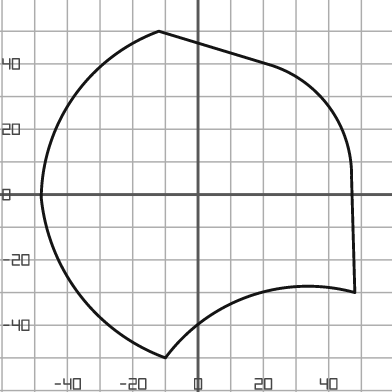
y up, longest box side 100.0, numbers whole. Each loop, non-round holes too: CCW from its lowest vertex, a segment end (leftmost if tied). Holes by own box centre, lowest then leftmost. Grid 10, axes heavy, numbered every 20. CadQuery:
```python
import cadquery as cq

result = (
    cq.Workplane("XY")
    .moveTo(-10.0, -50.0)
    .threePointArc((16.0, -31.0), (48.0, -30.0))
    .lineTo(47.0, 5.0)
    .threePointArc((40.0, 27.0), (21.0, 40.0))
    .lineTo(-12.0, 50.0)
    .threePointArc((-38.0, 30.0), (-48.0, -1.0))
    .threePointArc((-36.0, -31.0), (-10.0, -50.0))
    .close()
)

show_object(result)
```